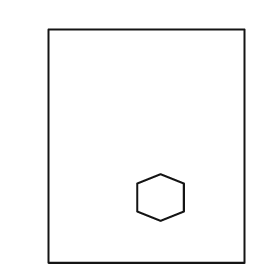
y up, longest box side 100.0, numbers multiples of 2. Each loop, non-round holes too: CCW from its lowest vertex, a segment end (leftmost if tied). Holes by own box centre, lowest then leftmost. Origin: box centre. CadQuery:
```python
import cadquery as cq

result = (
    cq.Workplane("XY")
    .moveTo(-42.0, -50.0)
    .lineTo(42.0, -50.0)
    .lineTo(42.0, 50.0)
    .lineTo(-42.0, 50.0)
    .close()
    .moveTo(6.0, -32.0)
    .lineTo(16.0, -28.0)
    .lineTo(16.0, -16.0)
    .lineTo(6.0, -12.0)
    .lineTo(-4.0, -16.0)
    .lineTo(-4.0, -28.0)
    .close()
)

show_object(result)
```